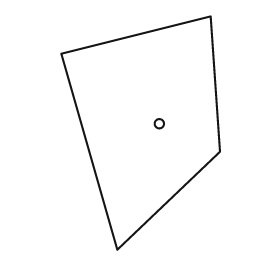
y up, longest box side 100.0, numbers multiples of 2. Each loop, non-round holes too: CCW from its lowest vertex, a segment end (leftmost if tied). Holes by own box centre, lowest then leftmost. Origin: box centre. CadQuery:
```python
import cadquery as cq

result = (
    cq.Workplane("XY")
    .moveTo(-10.0, -50.0)
    .lineTo(34.0, -8.0)
    .lineTo(30.0, 50.0)
    .lineTo(-34.0, 34.0)
    .close()
    .moveTo(8.0, 4.0)
    .circle(2.0)
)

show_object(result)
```